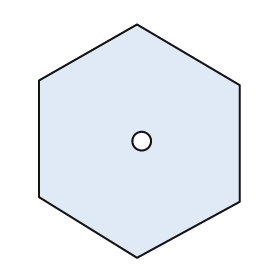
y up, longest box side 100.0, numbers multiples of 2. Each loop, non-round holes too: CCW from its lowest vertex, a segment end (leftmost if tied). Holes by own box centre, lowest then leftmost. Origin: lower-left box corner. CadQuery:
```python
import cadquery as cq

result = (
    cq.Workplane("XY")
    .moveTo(42.0, 0.0)
    .lineTo(86.0, 24.0)
    .lineTo(86.0, 74.0)
    .lineTo(42.0, 100.0)
    .lineTo(0.0, 76.0)
    .lineTo(0.0, 26.0)
    .close()
    .moveTo(44.0, 50.0)
    .circle(4.0)
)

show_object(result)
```